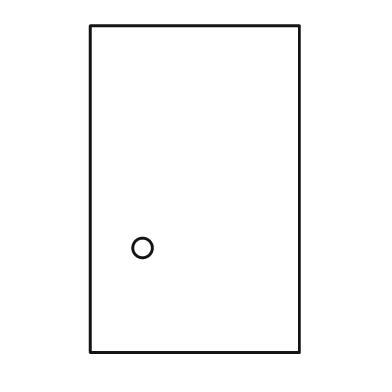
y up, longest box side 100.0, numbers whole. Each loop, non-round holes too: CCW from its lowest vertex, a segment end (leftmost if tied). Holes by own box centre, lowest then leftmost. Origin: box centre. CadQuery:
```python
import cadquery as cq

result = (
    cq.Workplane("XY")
    .moveTo(-32.0, -50.0)
    .lineTo(32.0, -50.0)
    .lineTo(32.0, 50.0)
    .lineTo(-32.0, 50.0)
    .close()
    .moveTo(-16.0, -18.0)
    .circle(3.0)
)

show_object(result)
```